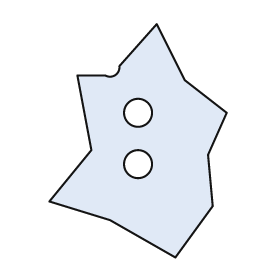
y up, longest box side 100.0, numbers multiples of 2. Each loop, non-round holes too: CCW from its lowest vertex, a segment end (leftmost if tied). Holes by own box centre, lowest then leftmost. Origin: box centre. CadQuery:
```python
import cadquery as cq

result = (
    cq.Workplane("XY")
    .moveTo(16.0, -50.0)
    .lineTo(32.0, -28.0)
    .lineTo(30.0, -6.0)
    .lineTo(38.0, 12.0)
    .lineTo(20.0, 26.0)
    .lineTo(8.0, 50.0)
    .lineTo(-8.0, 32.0)
    .threePointArc((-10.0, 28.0), (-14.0, 28.0))
    .lineTo(-26.0, 28.0)
    .lineTo(-20.0, -4.0)
    .lineTo(-38.0, -26.0)
    .lineTo(-12.0, -34.0)
    .close()
    .moveTo(0.0, -10.0)
    .circle(6.0)
    .moveTo(0.0, 12.0)
    .circle(6.0)
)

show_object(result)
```